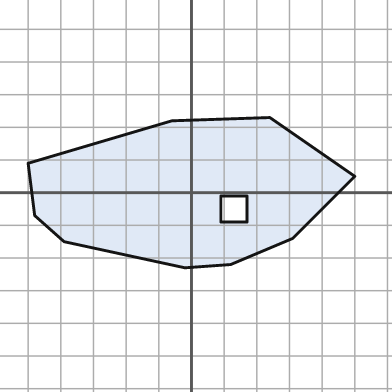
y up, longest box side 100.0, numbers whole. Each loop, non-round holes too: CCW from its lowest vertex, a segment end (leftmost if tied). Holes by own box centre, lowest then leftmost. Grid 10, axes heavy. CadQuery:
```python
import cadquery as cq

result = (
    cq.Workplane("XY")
    .moveTo(-2.0, -23.0)
    .lineTo(12.0, -22.0)
    .lineTo(31.0, -14.0)
    .lineTo(50.0, 5.0)
    .lineTo(24.0, 23.0)
    .lineTo(-6.0, 22.0)
    .lineTo(-50.0, 9.0)
    .lineTo(-48.0, -7.0)
    .lineTo(-39.0, -15.0)
    .close()
    .moveTo(9.0, -9.0)
    .lineTo(17.0, -9.0)
    .lineTo(17.0, -1.0)
    .lineTo(9.0, -1.0)
    .close()
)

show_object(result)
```